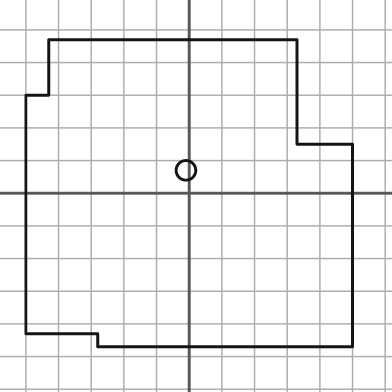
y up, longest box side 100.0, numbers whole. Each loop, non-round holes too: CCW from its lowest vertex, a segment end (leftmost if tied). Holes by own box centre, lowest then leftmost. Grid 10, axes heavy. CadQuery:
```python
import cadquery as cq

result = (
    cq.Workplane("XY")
    .moveTo(-28.0, -47.0)
    .lineTo(50.0, -47.0)
    .lineTo(50.0, 15.0)
    .lineTo(33.0, 15.0)
    .lineTo(33.0, 47.0)
    .lineTo(-43.0, 47.0)
    .lineTo(-43.0, 30.0)
    .lineTo(-50.0, 30.0)
    .lineTo(-50.0, -43.0)
    .lineTo(-28.0, -43.0)
    .close()
    .moveTo(-1.0, 7.0)
    .circle(3.0)
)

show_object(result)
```